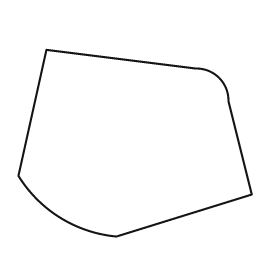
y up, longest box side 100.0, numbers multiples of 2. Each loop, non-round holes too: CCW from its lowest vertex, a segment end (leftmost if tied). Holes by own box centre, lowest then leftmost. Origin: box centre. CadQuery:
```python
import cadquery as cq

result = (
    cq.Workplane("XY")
    .moveTo(-8.0, -40.0)
    .lineTo(50.0, -22.0)
    .lineTo(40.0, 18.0)
    .threePointArc((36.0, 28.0), (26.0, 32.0))
    .lineTo(-38.0, 40.0)
    .lineTo(-50.0, -14.0)
    .threePointArc((-32.0, -32.0), (-8.0, -40.0))
    .close()
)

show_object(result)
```